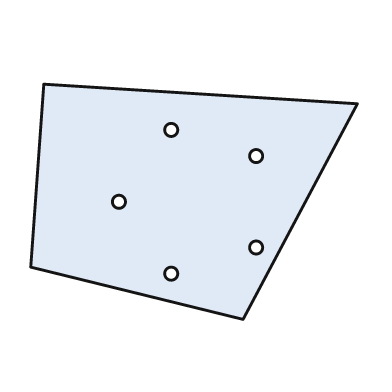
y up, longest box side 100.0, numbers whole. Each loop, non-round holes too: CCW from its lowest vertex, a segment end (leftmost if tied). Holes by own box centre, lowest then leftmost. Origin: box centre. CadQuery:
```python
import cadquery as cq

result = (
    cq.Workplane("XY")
    .moveTo(15.0, -36.0)
    .lineTo(50.0, 30.0)
    .lineTo(-46.0, 36.0)
    .lineTo(-50.0, -20.0)
    .close()
    .moveTo(-7.0, -22.0)
    .circle(2.0)
    .moveTo(19.0, -14.0)
    .circle(2.0)
    .moveTo(-23.0, 0.0)
    .circle(2.0)
    .moveTo(19.0, 14.0)
    .circle(2.0)
    .moveTo(-7.0, 22.0)
    .circle(2.0)
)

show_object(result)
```